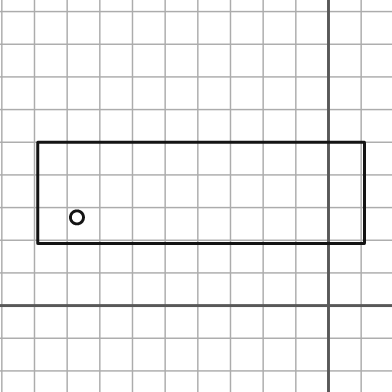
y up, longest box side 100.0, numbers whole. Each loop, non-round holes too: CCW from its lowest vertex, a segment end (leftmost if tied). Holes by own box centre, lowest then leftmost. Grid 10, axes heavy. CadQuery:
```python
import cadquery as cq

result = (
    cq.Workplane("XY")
    .moveTo(-89.0, 19.0)
    .lineTo(11.0, 19.0)
    .lineTo(11.0, 50.0)
    .lineTo(-89.0, 50.0)
    .close()
    .moveTo(-77.0, 27.0)
    .circle(2.0)
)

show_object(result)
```